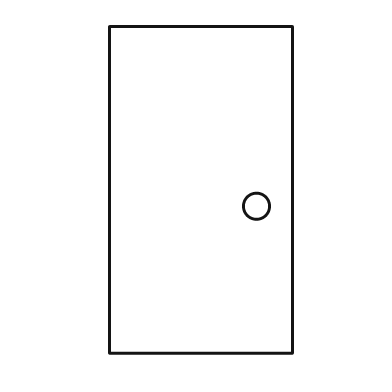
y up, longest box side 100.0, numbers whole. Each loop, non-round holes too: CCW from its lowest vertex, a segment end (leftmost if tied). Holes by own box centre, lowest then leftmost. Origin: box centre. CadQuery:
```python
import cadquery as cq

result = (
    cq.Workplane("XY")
    .moveTo(-28.0, -50.0)
    .lineTo(28.0, -50.0)
    .lineTo(28.0, 50.0)
    .lineTo(-28.0, 50.0)
    .close()
    .moveTo(17.0, -5.0)
    .circle(4.0)
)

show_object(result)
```